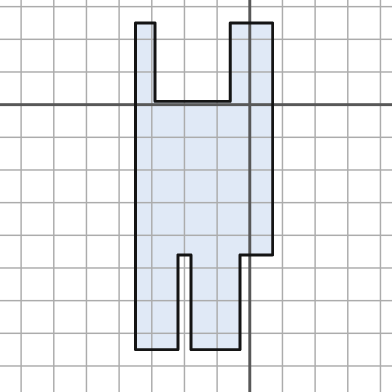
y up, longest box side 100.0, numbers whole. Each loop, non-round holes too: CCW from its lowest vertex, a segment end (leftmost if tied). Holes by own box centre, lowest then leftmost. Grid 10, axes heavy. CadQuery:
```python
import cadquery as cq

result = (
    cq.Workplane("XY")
    .moveTo(-35.0, -75.0)
    .lineTo(-22.0, -75.0)
    .lineTo(-22.0, -46.0)
    .lineTo(-18.0, -46.0)
    .lineTo(-18.0, -75.0)
    .lineTo(-3.0, -75.0)
    .lineTo(-3.0, -46.0)
    .lineTo(7.0, -46.0)
    .lineTo(7.0, 25.0)
    .lineTo(-6.0, 25.0)
    .lineTo(-6.0, 1.0)
    .lineTo(-29.0, 1.0)
    .lineTo(-29.0, 25.0)
    .lineTo(-35.0, 25.0)
    .close()
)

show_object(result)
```